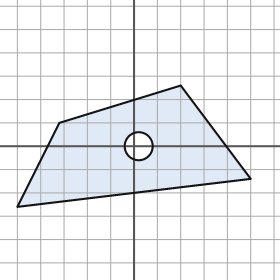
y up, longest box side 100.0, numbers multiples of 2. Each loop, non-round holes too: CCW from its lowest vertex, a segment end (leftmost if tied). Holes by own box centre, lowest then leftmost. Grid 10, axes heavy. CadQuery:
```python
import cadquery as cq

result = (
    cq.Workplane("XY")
    .moveTo(-50.0, -26.0)
    .lineTo(50.0, -14.0)
    .lineTo(20.0, 26.0)
    .lineTo(-32.0, 10.0)
    .close()
    .moveTo(2.0, 0.0)
    .circle(6.0)
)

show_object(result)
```